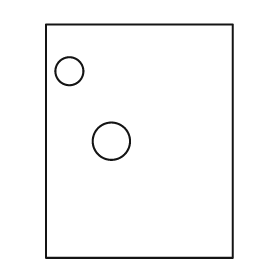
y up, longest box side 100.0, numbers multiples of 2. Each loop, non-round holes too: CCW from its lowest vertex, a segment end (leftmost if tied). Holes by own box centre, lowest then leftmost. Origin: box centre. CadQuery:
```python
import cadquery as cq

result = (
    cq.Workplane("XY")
    .moveTo(-40.0, -50.0)
    .lineTo(40.0, -50.0)
    .lineTo(40.0, 50.0)
    .lineTo(-40.0, 50.0)
    .close()
    .moveTo(-12.0, 0.0)
    .circle(8.0)
    .moveTo(-30.0, 30.0)
    .circle(6.0)
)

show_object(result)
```